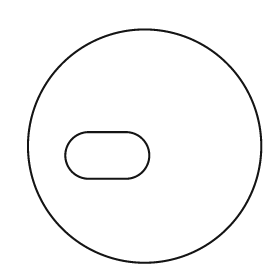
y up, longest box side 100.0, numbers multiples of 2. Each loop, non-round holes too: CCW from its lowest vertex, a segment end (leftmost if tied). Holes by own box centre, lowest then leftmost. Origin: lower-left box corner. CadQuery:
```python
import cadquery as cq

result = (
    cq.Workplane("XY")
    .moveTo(50.0, 50.0)
    .circle(50.0)
    .moveTo(26.0, 36.0)
    .lineTo(42.0, 36.0)
    .threePointArc((52.0, 46.0), (42.0, 56.0))
    .lineTo(26.0, 56.0)
    .threePointArc((16.0, 46.0), (26.0, 36.0))
    .close()
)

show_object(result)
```